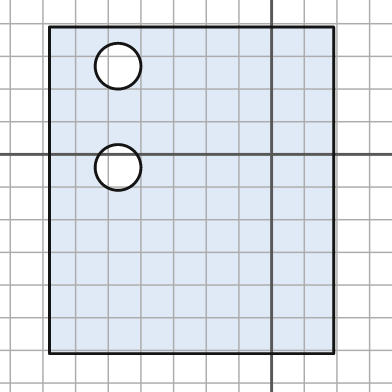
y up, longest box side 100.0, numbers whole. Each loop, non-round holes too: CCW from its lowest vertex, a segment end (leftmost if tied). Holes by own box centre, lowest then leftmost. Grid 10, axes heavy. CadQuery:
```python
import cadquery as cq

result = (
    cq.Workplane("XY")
    .moveTo(-68.0, -61.0)
    .lineTo(19.0, -61.0)
    .lineTo(19.0, 39.0)
    .lineTo(-68.0, 39.0)
    .close()
    .moveTo(-47.0, -4.0)
    .circle(7.0)
    .moveTo(-47.0, 27.0)
    .circle(7.0)
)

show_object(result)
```